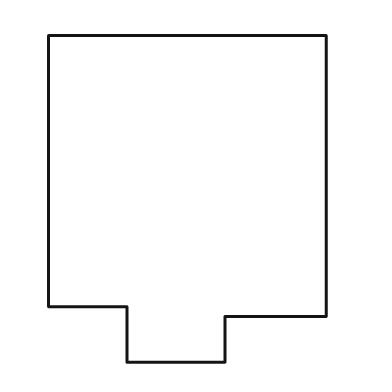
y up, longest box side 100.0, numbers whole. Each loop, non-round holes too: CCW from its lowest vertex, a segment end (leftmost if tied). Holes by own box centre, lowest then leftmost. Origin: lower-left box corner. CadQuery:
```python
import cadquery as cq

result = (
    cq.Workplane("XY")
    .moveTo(24.0, 0.0)
    .lineTo(54.0, 0.0)
    .lineTo(54.0, 14.0)
    .lineTo(85.0, 14.0)
    .lineTo(85.0, 100.0)
    .lineTo(0.0, 100.0)
    .lineTo(0.0, 17.0)
    .lineTo(24.0, 17.0)
    .close()
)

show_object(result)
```